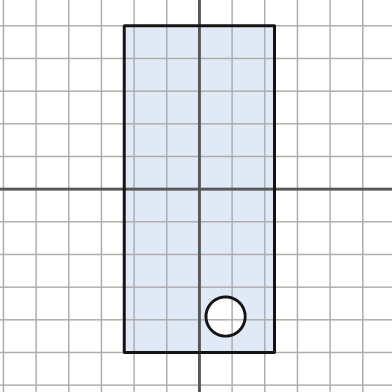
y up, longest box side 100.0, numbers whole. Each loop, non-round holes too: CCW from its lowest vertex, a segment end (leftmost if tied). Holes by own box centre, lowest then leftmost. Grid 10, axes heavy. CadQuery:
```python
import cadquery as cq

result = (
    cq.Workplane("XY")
    .moveTo(-23.0, -50.0)
    .lineTo(23.0, -50.0)
    .lineTo(23.0, 50.0)
    .lineTo(-23.0, 50.0)
    .close()
    .moveTo(8.0, -39.0)
    .circle(6.0)
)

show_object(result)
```